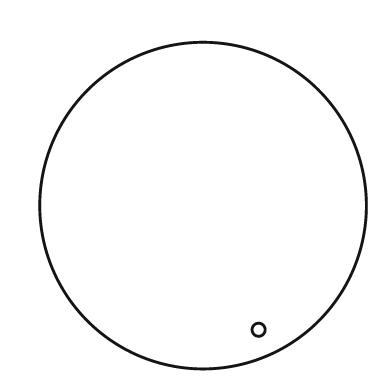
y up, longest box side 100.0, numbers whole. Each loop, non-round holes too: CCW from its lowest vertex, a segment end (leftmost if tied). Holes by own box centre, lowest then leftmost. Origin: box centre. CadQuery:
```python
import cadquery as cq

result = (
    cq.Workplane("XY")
    .moveTo(0.0, 0.0)
    .circle(50.0)
    .moveTo(17.0, -38.0)
    .circle(2.0)
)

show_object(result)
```